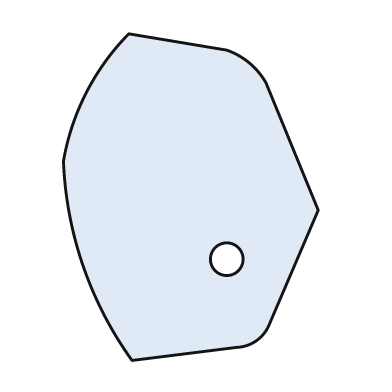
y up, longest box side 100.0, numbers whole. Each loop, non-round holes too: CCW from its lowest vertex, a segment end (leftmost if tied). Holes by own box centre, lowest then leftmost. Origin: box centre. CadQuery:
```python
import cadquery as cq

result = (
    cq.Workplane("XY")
    .moveTo(-18.0, -50.0)
    .lineTo(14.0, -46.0)
    .threePointArc((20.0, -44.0), (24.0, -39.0))
    .lineTo(39.0, -4.0)
    .lineTo(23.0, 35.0)
    .threePointArc((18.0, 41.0), (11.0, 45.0))
    .lineTo(-19.0, 50.0)
    .threePointArc((-32.0, 32.0), (-39.0, 11.0))
    .threePointArc((-33.0, -21.0), (-18.0, -50.0))
    .close()
    .moveTo(11.0, -19.0)
    .circle(5.0)
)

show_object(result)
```